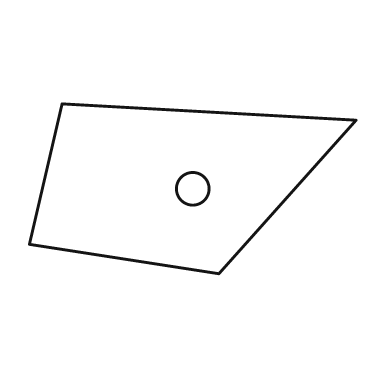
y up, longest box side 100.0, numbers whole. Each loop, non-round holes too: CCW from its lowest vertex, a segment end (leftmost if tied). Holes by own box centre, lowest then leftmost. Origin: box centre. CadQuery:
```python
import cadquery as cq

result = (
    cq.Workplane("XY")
    .moveTo(8.0, -26.0)
    .lineTo(50.0, 21.0)
    .lineTo(-40.0, 26.0)
    .lineTo(-50.0, -17.0)
    .close()
    .moveTo(0.0, 0.0)
    .circle(5.0)
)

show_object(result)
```